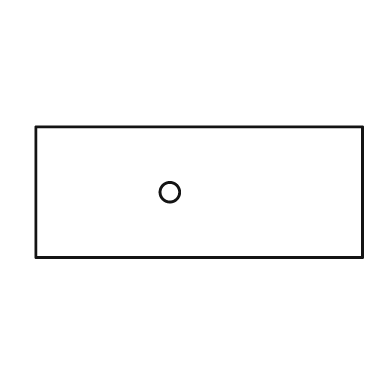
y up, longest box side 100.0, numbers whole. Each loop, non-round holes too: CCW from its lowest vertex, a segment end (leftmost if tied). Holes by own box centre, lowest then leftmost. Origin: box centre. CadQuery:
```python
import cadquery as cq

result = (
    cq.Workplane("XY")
    .moveTo(-50.0, -20.0)
    .lineTo(50.0, -20.0)
    .lineTo(50.0, 20.0)
    .lineTo(-50.0, 20.0)
    .close()
    .moveTo(-9.0, 0.0)
    .circle(3.0)
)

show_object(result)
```